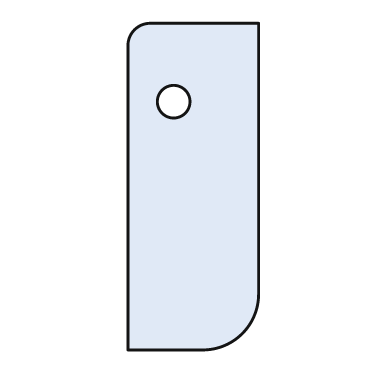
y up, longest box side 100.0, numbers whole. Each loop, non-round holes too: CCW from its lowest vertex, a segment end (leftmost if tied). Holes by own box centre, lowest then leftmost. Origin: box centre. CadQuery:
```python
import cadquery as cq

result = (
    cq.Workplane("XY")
    .moveTo(-20.0, -50.0)
    .lineTo(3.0, -50.0)
    .threePointArc((15.0, -45.0), (20.0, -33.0))
    .lineTo(20.0, 50.0)
    .lineTo(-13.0, 50.0)
    .threePointArc((-18.0, 48.0), (-20.0, 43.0))
    .close()
    .moveTo(-6.0, 26.0)
    .circle(5.0)
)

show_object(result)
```